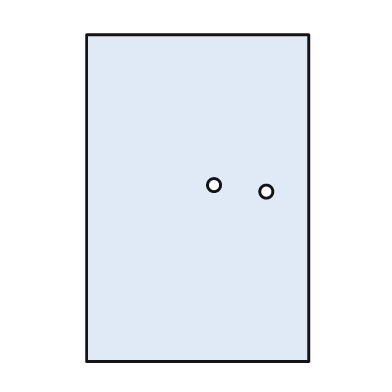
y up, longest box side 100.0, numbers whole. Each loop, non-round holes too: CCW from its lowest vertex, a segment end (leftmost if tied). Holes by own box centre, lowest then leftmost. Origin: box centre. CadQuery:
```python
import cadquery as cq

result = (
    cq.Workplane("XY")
    .moveTo(-34.0, -50.0)
    .lineTo(34.0, -50.0)
    .lineTo(34.0, 50.0)
    .lineTo(-34.0, 50.0)
    .close()
    .moveTo(21.0, 2.0)
    .circle(2.0)
    .moveTo(5.0, 4.0)
    .circle(2.0)
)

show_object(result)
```